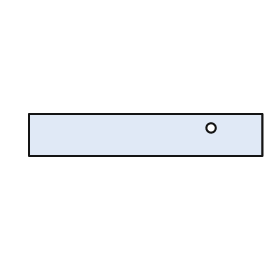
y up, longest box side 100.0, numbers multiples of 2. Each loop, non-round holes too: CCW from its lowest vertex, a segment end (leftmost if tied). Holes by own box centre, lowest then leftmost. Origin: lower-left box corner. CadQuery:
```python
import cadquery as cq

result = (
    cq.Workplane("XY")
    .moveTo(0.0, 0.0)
    .lineTo(100.0, 0.0)
    .lineTo(100.0, 18.0)
    .lineTo(0.0, 18.0)
    .close()
    .moveTo(78.0, 12.0)
    .circle(2.0)
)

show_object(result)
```